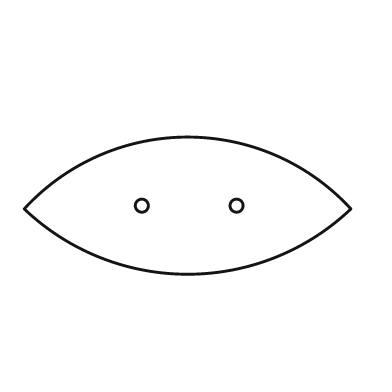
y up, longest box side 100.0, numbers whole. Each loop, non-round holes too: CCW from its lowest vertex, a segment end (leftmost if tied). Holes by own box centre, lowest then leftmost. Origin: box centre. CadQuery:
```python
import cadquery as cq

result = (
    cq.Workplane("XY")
    .moveTo(-50.0, -1.0)
    .threePointArc((0.0, -21.0), (50.0, -1.0))
    .threePointArc((0.0, 21.0), (-50.0, -1.0))
    .close()
    .moveTo(-14.0, 0.0)
    .circle(2.0)
    .moveTo(15.0, 0.0)
    .circle(2.0)
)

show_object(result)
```